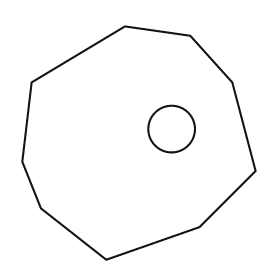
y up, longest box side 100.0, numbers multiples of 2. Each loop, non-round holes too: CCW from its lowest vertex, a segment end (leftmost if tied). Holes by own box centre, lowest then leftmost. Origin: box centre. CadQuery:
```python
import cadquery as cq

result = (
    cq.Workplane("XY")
    .moveTo(-14.0, -50.0)
    .lineTo(26.0, -36.0)
    .lineTo(50.0, -12.0)
    .lineTo(40.0, 26.0)
    .lineTo(22.0, 46.0)
    .lineTo(-6.0, 50.0)
    .lineTo(-46.0, 26.0)
    .lineTo(-50.0, -8.0)
    .lineTo(-42.0, -28.0)
    .close()
    .moveTo(14.0, 6.0)
    .circle(10.0)
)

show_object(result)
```